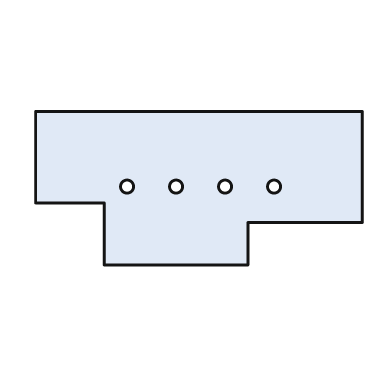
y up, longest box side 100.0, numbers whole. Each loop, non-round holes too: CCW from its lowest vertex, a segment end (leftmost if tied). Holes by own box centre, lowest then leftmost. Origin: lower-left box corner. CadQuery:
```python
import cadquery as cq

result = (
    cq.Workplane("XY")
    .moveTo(21.0, 0.0)
    .lineTo(65.0, 0.0)
    .lineTo(65.0, 13.0)
    .lineTo(100.0, 13.0)
    .lineTo(100.0, 47.0)
    .lineTo(0.0, 47.0)
    .lineTo(0.0, 19.0)
    .lineTo(21.0, 19.0)
    .close()
    .moveTo(28.0, 24.0)
    .circle(2.0)
    .moveTo(43.0, 24.0)
    .circle(2.0)
    .moveTo(58.0, 24.0)
    .circle(2.0)
    .moveTo(73.0, 24.0)
    .circle(2.0)
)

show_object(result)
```